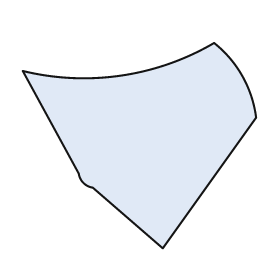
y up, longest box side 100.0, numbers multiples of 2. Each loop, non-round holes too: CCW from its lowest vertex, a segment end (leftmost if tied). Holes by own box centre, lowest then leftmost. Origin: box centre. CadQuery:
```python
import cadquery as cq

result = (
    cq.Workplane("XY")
    .moveTo(10.0, -44.0)
    .lineTo(50.0, 12.0)
    .threePointArc((44.0, 30.0), (32.0, 44.0))
    .threePointArc((-8.0, 30.0), (-50.0, 32.0))
    .lineTo(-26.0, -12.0)
    .threePointArc((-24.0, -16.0), (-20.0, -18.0))
    .close()
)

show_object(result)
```